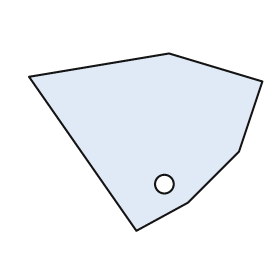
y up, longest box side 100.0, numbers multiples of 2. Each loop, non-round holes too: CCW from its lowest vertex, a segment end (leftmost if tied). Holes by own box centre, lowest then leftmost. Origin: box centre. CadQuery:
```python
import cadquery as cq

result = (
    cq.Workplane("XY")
    .moveTo(-4.0, -38.0)
    .lineTo(18.0, -26.0)
    .lineTo(40.0, -4.0)
    .lineTo(50.0, 26.0)
    .lineTo(10.0, 38.0)
    .lineTo(-50.0, 28.0)
    .close()
    .moveTo(8.0, -18.0)
    .circle(4.0)
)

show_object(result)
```